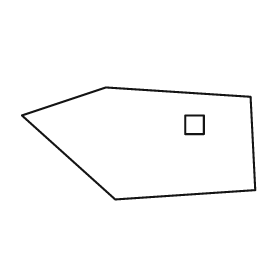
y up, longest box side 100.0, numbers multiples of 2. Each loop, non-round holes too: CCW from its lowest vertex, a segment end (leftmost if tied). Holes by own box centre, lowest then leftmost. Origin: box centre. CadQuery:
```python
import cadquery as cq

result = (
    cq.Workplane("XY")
    .moveTo(-10.0, -24.0)
    .lineTo(50.0, -20.0)
    .lineTo(48.0, 20.0)
    .lineTo(-14.0, 24.0)
    .lineTo(-50.0, 12.0)
    .close()
    .moveTo(20.0, 4.0)
    .lineTo(28.0, 4.0)
    .lineTo(28.0, 12.0)
    .lineTo(20.0, 12.0)
    .close()
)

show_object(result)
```